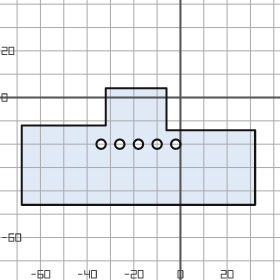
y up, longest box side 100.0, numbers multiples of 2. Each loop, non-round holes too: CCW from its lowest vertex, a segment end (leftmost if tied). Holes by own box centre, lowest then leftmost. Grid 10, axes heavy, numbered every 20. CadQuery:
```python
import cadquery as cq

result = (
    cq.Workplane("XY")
    .moveTo(-68.0, -46.0)
    .lineTo(32.0, -46.0)
    .lineTo(32.0, -14.0)
    .lineTo(-6.0, -14.0)
    .lineTo(-6.0, 4.0)
    .lineTo(-32.0, 4.0)
    .lineTo(-32.0, -12.0)
    .lineTo(-68.0, -12.0)
    .close()
    .moveTo(-34.0, -20.0)
    .circle(2.0)
    .moveTo(-26.0, -20.0)
    .circle(2.0)
    .moveTo(-18.0, -20.0)
    .circle(2.0)
    .moveTo(-10.0, -20.0)
    .circle(2.0)
    .moveTo(-2.0, -20.0)
    .circle(2.0)
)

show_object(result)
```